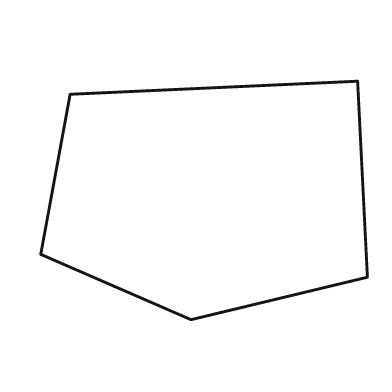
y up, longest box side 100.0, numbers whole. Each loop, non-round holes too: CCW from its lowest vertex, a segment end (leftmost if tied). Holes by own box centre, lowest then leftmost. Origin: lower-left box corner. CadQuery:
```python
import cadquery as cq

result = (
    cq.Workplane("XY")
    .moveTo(46.0, 0.0)
    .lineTo(100.0, 13.0)
    .lineTo(97.0, 73.0)
    .lineTo(9.0, 69.0)
    .lineTo(0.0, 20.0)
    .close()
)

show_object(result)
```